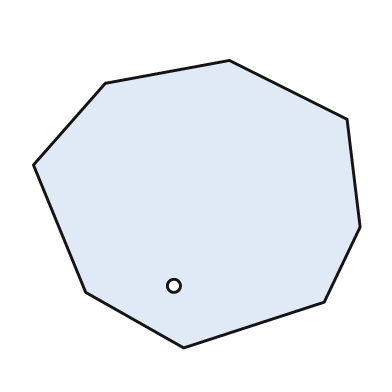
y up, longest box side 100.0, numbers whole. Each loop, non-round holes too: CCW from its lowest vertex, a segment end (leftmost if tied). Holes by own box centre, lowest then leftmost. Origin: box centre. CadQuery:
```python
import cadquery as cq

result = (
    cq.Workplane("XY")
    .moveTo(-4.0, -44.0)
    .lineTo(39.0, -30.0)
    .lineTo(50.0, -7.0)
    .lineTo(46.0, 26.0)
    .lineTo(10.0, 44.0)
    .lineTo(-28.0, 37.0)
    .lineTo(-50.0, 12.0)
    .lineTo(-34.0, -27.0)
    .close()
    .moveTo(-7.0, -25.0)
    .circle(2.0)
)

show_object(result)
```